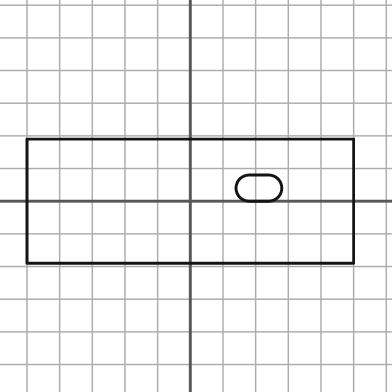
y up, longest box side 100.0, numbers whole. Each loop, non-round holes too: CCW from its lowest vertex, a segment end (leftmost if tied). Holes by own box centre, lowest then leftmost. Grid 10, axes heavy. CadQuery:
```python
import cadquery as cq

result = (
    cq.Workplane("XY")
    .moveTo(-50.0, -19.0)
    .lineTo(50.0, -19.0)
    .lineTo(50.0, 19.0)
    .lineTo(-50.0, 19.0)
    .close()
    .moveTo(18.0, 0.0)
    .lineTo(24.0, 0.0)
    .threePointArc((28.0, 4.0), (24.0, 8.0))
    .lineTo(18.0, 8.0)
    .threePointArc((14.0, 4.0), (18.0, 0.0))
    .close()
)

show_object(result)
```